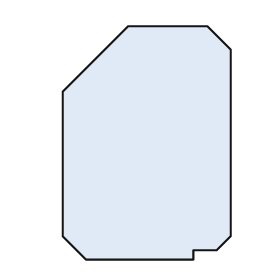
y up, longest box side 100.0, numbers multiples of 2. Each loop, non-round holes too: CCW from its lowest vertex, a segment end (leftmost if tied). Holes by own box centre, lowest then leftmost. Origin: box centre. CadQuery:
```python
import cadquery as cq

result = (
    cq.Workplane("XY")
    .moveTo(-26.0, -50.0)
    .lineTo(20.0, -50.0)
    .lineTo(20.0, -46.0)
    .lineTo(30.0, -46.0)
    .lineTo(36.0, -40.0)
    .lineTo(36.0, 40.0)
    .lineTo(26.0, 50.0)
    .lineTo(-8.0, 50.0)
    .lineTo(-36.0, 22.0)
    .lineTo(-36.0, -40.0)
    .close()
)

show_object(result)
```